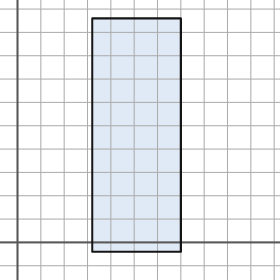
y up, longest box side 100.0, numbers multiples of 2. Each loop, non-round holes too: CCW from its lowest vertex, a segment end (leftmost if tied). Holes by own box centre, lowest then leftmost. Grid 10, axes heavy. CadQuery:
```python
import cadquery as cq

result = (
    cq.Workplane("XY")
    .moveTo(32.0, -4.0)
    .lineTo(70.0, -4.0)
    .lineTo(70.0, 96.0)
    .lineTo(32.0, 96.0)
    .close()
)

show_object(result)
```